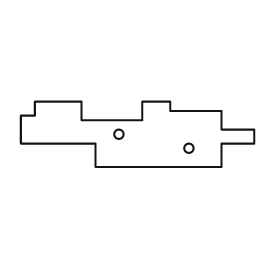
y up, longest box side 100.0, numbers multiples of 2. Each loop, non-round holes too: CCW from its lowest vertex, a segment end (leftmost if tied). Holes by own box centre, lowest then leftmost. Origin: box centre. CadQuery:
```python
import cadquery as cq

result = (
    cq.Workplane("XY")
    .moveTo(-18.0, -14.0)
    .lineTo(36.0, -14.0)
    .lineTo(36.0, -4.0)
    .lineTo(50.0, -4.0)
    .lineTo(50.0, 2.0)
    .lineTo(36.0, 2.0)
    .lineTo(36.0, 10.0)
    .lineTo(14.0, 10.0)
    .lineTo(14.0, 14.0)
    .lineTo(2.0, 14.0)
    .lineTo(2.0, 6.0)
    .lineTo(-24.0, 6.0)
    .lineTo(-24.0, 14.0)
    .lineTo(-44.0, 14.0)
    .lineTo(-44.0, 8.0)
    .lineTo(-50.0, 8.0)
    .lineTo(-50.0, -4.0)
    .lineTo(-18.0, -4.0)
    .close()
    .moveTo(22.0, -6.0)
    .circle(2.0)
    .moveTo(-8.0, 0.0)
    .circle(2.0)
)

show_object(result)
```